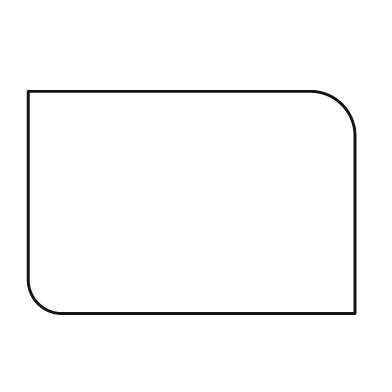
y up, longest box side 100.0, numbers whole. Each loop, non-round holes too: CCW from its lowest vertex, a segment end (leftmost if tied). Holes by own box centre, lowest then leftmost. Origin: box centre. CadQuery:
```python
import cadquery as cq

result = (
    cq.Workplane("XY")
    .moveTo(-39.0, -34.0)
    .lineTo(50.0, -34.0)
    .lineTo(50.0, 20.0)
    .threePointArc((46.0, 30.0), (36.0, 34.0))
    .lineTo(-50.0, 34.0)
    .lineTo(-50.0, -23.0)
    .threePointArc((-47.0, -31.0), (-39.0, -34.0))
    .close()
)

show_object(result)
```